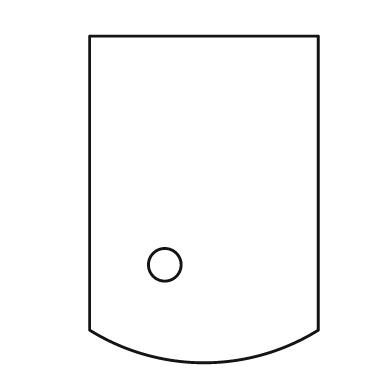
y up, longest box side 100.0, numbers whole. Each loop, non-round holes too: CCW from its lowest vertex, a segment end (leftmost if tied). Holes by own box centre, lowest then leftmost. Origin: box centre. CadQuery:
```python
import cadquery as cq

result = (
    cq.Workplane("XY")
    .moveTo(-35.0, -40.0)
    .threePointArc((0.0, -50.0), (35.0, -40.0))
    .lineTo(35.0, 50.0)
    .lineTo(-35.0, 50.0)
    .close()
    .moveTo(-12.0, -20.0)
    .circle(5.0)
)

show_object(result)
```